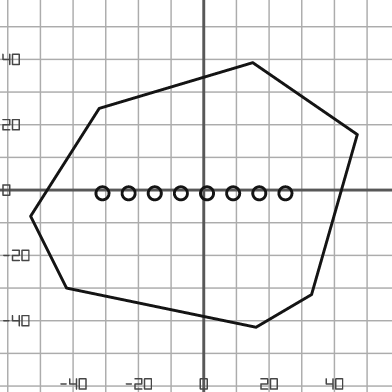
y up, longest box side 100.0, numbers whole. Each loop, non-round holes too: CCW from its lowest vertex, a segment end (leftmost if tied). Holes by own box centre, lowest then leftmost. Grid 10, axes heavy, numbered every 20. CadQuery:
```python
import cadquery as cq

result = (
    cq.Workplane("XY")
    .moveTo(16.0, -42.0)
    .lineTo(33.0, -32.0)
    .lineTo(47.0, 17.0)
    .lineTo(15.0, 39.0)
    .lineTo(-32.0, 25.0)
    .lineTo(-53.0, -8.0)
    .lineTo(-42.0, -30.0)
    .close()
    .moveTo(-31.0, -1.0)
    .circle(2.0)
    .moveTo(-23.0, -1.0)
    .circle(2.0)
    .moveTo(-15.0, -1.0)
    .circle(2.0)
    .moveTo(-7.0, -1.0)
    .circle(2.0)
    .moveTo(1.0, -1.0)
    .circle(2.0)
    .moveTo(9.0, -1.0)
    .circle(2.0)
    .moveTo(17.0, -1.0)
    .circle(2.0)
    .moveTo(25.0, -1.0)
    .circle(2.0)
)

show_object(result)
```